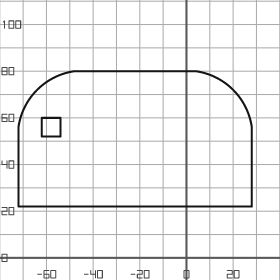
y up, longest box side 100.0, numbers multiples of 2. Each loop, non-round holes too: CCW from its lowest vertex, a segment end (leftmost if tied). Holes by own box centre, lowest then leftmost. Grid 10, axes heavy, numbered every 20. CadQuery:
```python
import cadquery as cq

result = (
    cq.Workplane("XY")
    .moveTo(-72.0, 22.0)
    .lineTo(28.0, 22.0)
    .lineTo(28.0, 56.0)
    .threePointArc((20.0, 72.0), (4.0, 80.0))
    .lineTo(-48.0, 80.0)
    .threePointArc((-64.0, 72.0), (-72.0, 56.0))
    .close()
    .moveTo(-62.0, 52.0)
    .lineTo(-54.0, 52.0)
    .lineTo(-54.0, 60.0)
    .lineTo(-62.0, 60.0)
    .close()
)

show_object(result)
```